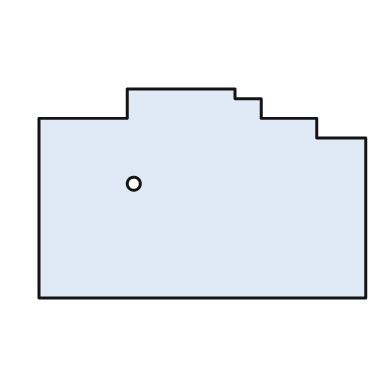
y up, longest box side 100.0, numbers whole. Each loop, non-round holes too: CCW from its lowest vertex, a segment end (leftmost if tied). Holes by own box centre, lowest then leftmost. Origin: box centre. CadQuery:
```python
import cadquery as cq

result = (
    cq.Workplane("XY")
    .moveTo(-50.0, -32.0)
    .lineTo(50.0, -32.0)
    .lineTo(50.0, 17.0)
    .lineTo(35.0, 17.0)
    .lineTo(35.0, 23.0)
    .lineTo(18.0, 23.0)
    .lineTo(18.0, 29.0)
    .lineTo(10.0, 29.0)
    .lineTo(10.0, 32.0)
    .lineTo(-23.0, 32.0)
    .lineTo(-23.0, 23.0)
    .lineTo(-50.0, 23.0)
    .close()
    .moveTo(-21.0, 3.0)
    .circle(2.0)
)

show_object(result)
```